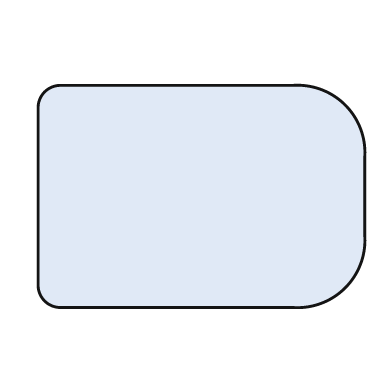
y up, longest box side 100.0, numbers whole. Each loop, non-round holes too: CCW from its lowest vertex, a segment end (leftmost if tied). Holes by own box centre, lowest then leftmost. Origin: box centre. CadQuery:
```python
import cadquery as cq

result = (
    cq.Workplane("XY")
    .moveTo(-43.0, -34.0)
    .lineTo(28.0, -34.0)
    .threePointArc((44.0, -28.0), (50.0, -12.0))
    .lineTo(50.0, 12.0)
    .threePointArc((44.0, 28.0), (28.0, 34.0))
    .lineTo(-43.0, 34.0)
    .threePointArc((-48.0, 32.0), (-50.0, 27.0))
    .lineTo(-50.0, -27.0)
    .threePointArc((-48.0, -32.0), (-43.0, -34.0))
    .close()
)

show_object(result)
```